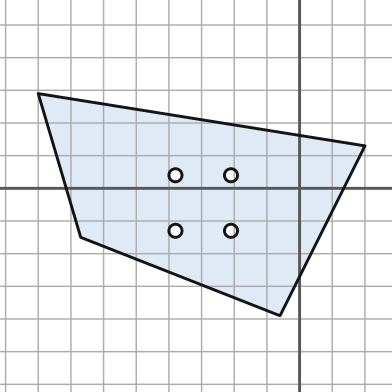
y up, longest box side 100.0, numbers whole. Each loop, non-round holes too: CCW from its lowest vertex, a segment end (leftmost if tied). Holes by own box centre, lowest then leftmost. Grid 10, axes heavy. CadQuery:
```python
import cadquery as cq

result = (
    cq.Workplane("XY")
    .moveTo(-6.0, -39.0)
    .lineTo(20.0, 13.0)
    .lineTo(-80.0, 29.0)
    .lineTo(-67.0, -15.0)
    .close()
    .moveTo(-38.0, -13.0)
    .circle(2.0)
    .moveTo(-21.0, -13.0)
    .circle(2.0)
    .moveTo(-38.0, 4.0)
    .circle(2.0)
    .moveTo(-21.0, 4.0)
    .circle(2.0)
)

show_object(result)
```